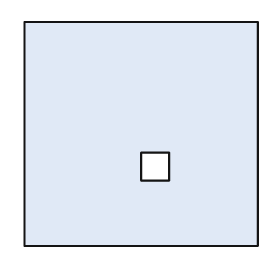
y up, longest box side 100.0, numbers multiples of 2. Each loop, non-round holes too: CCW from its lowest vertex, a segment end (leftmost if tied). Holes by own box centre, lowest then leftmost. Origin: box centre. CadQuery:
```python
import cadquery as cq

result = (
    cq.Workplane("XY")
    .moveTo(-50.0, -48.0)
    .lineTo(50.0, -48.0)
    .lineTo(50.0, 48.0)
    .lineTo(-50.0, 48.0)
    .close()
    .moveTo(0.0, -20.0)
    .lineTo(12.0, -20.0)
    .lineTo(12.0, -8.0)
    .lineTo(0.0, -8.0)
    .close()
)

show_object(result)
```